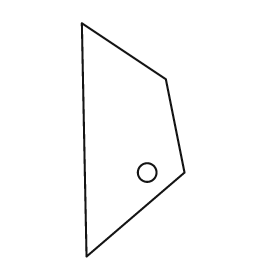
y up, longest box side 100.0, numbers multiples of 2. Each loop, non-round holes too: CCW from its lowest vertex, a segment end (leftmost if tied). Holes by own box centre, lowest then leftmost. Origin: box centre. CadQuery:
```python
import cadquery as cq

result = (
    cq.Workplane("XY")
    .moveTo(-20.0, -50.0)
    .lineTo(22.0, -14.0)
    .lineTo(14.0, 26.0)
    .lineTo(-22.0, 50.0)
    .close()
    .moveTo(6.0, -14.0)
    .circle(4.0)
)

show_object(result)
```